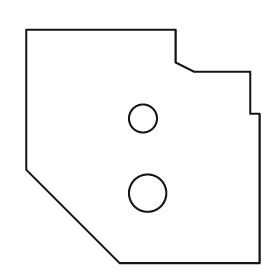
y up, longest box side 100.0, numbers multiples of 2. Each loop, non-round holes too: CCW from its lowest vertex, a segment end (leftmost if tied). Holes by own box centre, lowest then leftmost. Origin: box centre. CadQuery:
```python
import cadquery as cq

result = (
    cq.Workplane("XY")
    .moveTo(-10.0, -50.0)
    .lineTo(50.0, -50.0)
    .lineTo(50.0, 14.0)
    .lineTo(46.0, 14.0)
    .lineTo(46.0, 32.0)
    .lineTo(22.0, 32.0)
    .lineTo(14.0, 36.0)
    .lineTo(14.0, 50.0)
    .lineTo(-50.0, 50.0)
    .lineTo(-50.0, -10.0)
    .close()
    .moveTo(2.0, -20.0)
    .circle(8.0)
    .moveTo(0.0, 12.0)
    .circle(6.0)
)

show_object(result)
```